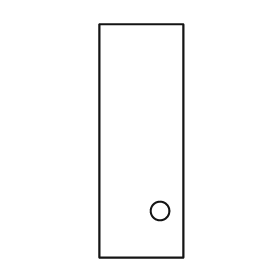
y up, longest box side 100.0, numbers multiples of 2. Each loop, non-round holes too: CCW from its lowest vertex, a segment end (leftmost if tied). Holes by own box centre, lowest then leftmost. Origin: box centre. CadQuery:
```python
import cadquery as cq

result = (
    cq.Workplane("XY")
    .moveTo(-18.0, -50.0)
    .lineTo(18.0, -50.0)
    .lineTo(18.0, 50.0)
    .lineTo(-18.0, 50.0)
    .close()
    .moveTo(8.0, -30.0)
    .circle(4.0)
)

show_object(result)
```